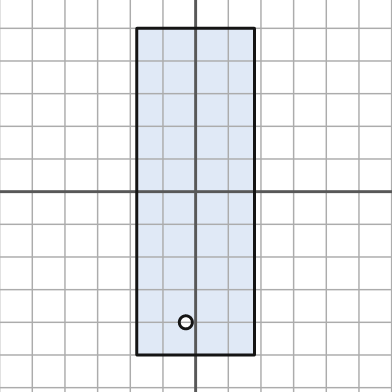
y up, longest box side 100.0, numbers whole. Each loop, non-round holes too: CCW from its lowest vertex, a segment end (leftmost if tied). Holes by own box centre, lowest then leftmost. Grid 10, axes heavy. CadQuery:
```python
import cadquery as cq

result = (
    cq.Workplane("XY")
    .moveTo(-18.0, -50.0)
    .lineTo(18.0, -50.0)
    .lineTo(18.0, 50.0)
    .lineTo(-18.0, 50.0)
    .close()
    .moveTo(-3.0, -40.0)
    .circle(2.0)
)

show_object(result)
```